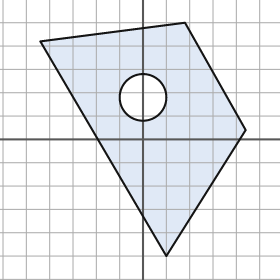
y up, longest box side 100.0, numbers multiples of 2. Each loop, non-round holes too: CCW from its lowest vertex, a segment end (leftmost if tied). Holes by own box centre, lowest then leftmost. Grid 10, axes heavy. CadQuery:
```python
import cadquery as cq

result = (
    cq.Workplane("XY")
    .moveTo(10.0, -50.0)
    .lineTo(44.0, 4.0)
    .lineTo(18.0, 50.0)
    .lineTo(-44.0, 42.0)
    .close()
    .moveTo(0.0, 18.0)
    .circle(10.0)
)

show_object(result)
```